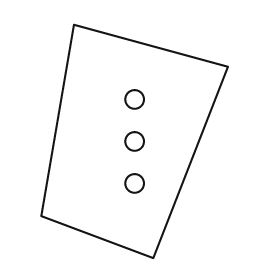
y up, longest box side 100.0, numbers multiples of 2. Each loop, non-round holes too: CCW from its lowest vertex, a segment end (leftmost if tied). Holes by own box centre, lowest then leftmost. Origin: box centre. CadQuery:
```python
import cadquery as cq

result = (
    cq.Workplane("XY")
    .moveTo(8.0, -50.0)
    .lineTo(40.0, 32.0)
    .lineTo(-26.0, 50.0)
    .lineTo(-40.0, -32.0)
    .close()
    .moveTo(0.0, -18.0)
    .circle(4.0)
    .moveTo(0.0, 0.0)
    .circle(4.0)
    .moveTo(0.0, 18.0)
    .circle(4.0)
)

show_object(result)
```